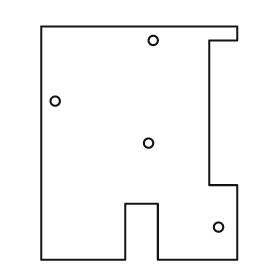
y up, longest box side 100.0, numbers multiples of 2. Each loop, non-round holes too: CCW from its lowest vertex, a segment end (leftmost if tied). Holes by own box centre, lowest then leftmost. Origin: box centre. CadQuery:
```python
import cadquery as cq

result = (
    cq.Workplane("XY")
    .moveTo(-42.0, -50.0)
    .lineTo(-6.0, -50.0)
    .lineTo(-6.0, -26.0)
    .lineTo(8.0, -26.0)
    .lineTo(8.0, -50.0)
    .lineTo(42.0, -50.0)
    .lineTo(42.0, -18.0)
    .lineTo(30.0, -18.0)
    .lineTo(30.0, 44.0)
    .lineTo(42.0, 44.0)
    .lineTo(42.0, 50.0)
    .lineTo(-42.0, 50.0)
    .close()
    .moveTo(34.0, -36.0)
    .circle(2.0)
    .moveTo(4.0, 0.0)
    .circle(2.0)
    .moveTo(-36.0, 18.0)
    .circle(2.0)
    .moveTo(6.0, 44.0)
    .circle(2.0)
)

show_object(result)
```